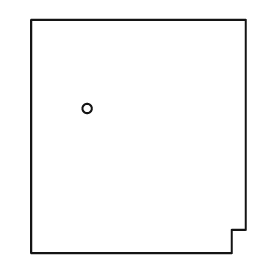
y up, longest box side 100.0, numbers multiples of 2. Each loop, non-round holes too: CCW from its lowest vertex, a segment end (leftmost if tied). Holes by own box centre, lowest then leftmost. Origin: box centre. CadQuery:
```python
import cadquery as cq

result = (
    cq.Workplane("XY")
    .moveTo(-46.0, -50.0)
    .lineTo(40.0, -50.0)
    .lineTo(40.0, -40.0)
    .lineTo(46.0, -40.0)
    .lineTo(46.0, 50.0)
    .lineTo(-46.0, 50.0)
    .close()
    .moveTo(-22.0, 12.0)
    .circle(2.0)
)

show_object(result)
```